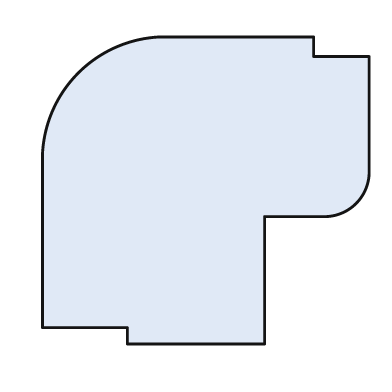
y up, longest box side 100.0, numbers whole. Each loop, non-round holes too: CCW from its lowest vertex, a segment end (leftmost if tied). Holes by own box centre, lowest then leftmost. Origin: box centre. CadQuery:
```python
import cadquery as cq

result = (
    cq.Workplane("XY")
    .moveTo(-24.0, -47.0)
    .lineTo(18.0, -47.0)
    .lineTo(18.0, -8.0)
    .lineTo(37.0, -8.0)
    .threePointArc((46.0, -4.0), (50.0, 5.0))
    .lineTo(50.0, 41.0)
    .lineTo(33.0, 41.0)
    .lineTo(33.0, 47.0)
    .lineTo(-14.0, 47.0)
    .threePointArc((-39.0, 36.0), (-50.0, 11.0))
    .lineTo(-50.0, -42.0)
    .lineTo(-24.0, -42.0)
    .close()
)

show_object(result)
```